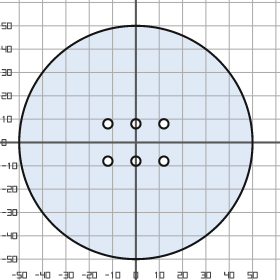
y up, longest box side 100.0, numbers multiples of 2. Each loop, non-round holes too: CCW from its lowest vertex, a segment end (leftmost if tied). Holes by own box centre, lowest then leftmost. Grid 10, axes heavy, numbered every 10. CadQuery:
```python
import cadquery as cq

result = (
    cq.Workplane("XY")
    .moveTo(0.0, 0.0)
    .circle(50.0)
    .moveTo(-12.0, -8.0)
    .circle(2.0)
    .moveTo(0.0, -8.0)
    .circle(2.0)
    .moveTo(12.0, -8.0)
    .circle(2.0)
    .moveTo(-12.0, 8.0)
    .circle(2.0)
    .moveTo(0.0, 8.0)
    .circle(2.0)
    .moveTo(12.0, 8.0)
    .circle(2.0)
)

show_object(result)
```